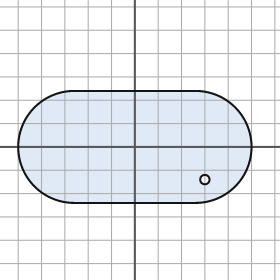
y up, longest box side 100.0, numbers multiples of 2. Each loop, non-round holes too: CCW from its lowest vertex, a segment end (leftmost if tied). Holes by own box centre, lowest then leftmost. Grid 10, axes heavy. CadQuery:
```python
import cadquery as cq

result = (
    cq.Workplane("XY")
    .moveTo(-26.0, -24.0)
    .lineTo(26.0, -24.0)
    .threePointArc((50.0, 0.0), (26.0, 24.0))
    .lineTo(-26.0, 24.0)
    .threePointArc((-50.0, 0.0), (-26.0, -24.0))
    .close()
    .moveTo(30.0, -14.0)
    .circle(2.0)
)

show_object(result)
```